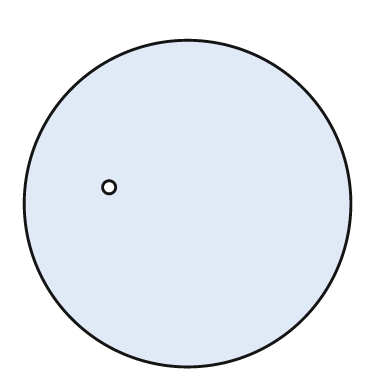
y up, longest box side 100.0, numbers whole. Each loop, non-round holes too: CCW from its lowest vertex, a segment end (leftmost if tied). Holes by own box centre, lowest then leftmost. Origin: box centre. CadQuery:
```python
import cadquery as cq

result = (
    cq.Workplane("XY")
    .moveTo(0.0, 0.0)
    .circle(50.0)
    .moveTo(-24.0, 5.0)
    .circle(2.0)
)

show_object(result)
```